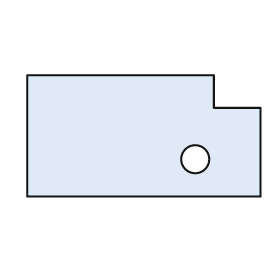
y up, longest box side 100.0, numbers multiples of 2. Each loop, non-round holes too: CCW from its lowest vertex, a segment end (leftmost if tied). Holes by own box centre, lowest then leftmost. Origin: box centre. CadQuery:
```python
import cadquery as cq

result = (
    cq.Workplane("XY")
    .moveTo(-50.0, -26.0)
    .lineTo(50.0, -26.0)
    .lineTo(50.0, 12.0)
    .lineTo(30.0, 12.0)
    .lineTo(30.0, 26.0)
    .lineTo(-50.0, 26.0)
    .close()
    .moveTo(22.0, -10.0)
    .circle(6.0)
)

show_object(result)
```